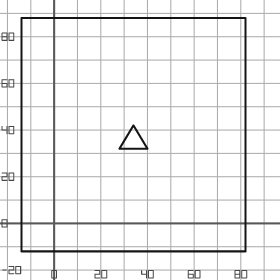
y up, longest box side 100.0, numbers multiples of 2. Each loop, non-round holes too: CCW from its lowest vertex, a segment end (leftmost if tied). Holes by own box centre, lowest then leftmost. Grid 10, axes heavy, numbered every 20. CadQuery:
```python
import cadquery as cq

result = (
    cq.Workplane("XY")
    .moveTo(-14.0, -12.0)
    .lineTo(82.0, -12.0)
    .lineTo(82.0, 88.0)
    .lineTo(-14.0, 88.0)
    .close()
    .moveTo(28.0, 32.0)
    .lineTo(40.0, 32.0)
    .lineTo(34.0, 42.0)
    .close()
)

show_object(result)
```